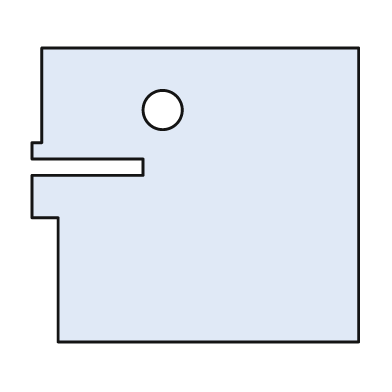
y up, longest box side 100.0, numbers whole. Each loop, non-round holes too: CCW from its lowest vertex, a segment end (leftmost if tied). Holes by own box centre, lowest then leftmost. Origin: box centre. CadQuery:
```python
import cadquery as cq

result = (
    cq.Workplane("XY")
    .moveTo(-42.0, -45.0)
    .lineTo(50.0, -45.0)
    .lineTo(50.0, 45.0)
    .lineTo(-47.0, 45.0)
    .lineTo(-47.0, 16.0)
    .lineTo(-50.0, 16.0)
    .lineTo(-50.0, 11.0)
    .lineTo(-16.0, 11.0)
    .lineTo(-16.0, 6.0)
    .lineTo(-50.0, 6.0)
    .lineTo(-50.0, -7.0)
    .lineTo(-42.0, -7.0)
    .close()
    .moveTo(-10.0, 26.0)
    .circle(6.0)
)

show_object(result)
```